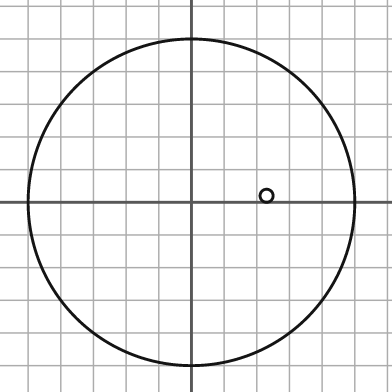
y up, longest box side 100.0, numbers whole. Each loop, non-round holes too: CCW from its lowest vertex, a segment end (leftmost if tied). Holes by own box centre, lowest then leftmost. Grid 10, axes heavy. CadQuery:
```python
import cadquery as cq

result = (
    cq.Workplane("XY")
    .moveTo(0.0, 0.0)
    .circle(50.0)
    .moveTo(23.0, 2.0)
    .circle(2.0)
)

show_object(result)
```